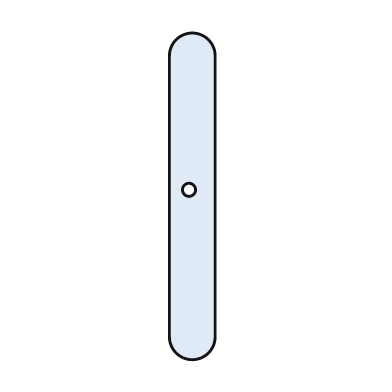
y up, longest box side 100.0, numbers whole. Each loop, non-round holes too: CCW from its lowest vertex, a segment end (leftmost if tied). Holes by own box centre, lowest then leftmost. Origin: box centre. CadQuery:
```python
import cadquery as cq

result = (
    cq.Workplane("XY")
    .moveTo(-7.0, -43.0)
    .threePointArc((0.0, -50.0), (7.0, -43.0))
    .lineTo(7.0, 43.0)
    .threePointArc((0.0, 50.0), (-7.0, 43.0))
    .close()
    .moveTo(-1.0, 2.0)
    .circle(2.0)
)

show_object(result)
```